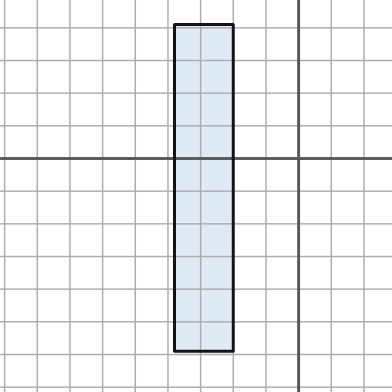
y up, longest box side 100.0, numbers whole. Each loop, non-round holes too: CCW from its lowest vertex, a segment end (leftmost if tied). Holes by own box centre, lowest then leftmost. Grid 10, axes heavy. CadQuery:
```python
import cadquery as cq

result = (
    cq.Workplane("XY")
    .moveTo(-38.0, -59.0)
    .lineTo(-20.0, -59.0)
    .lineTo(-20.0, 41.0)
    .lineTo(-38.0, 41.0)
    .close()
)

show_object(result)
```